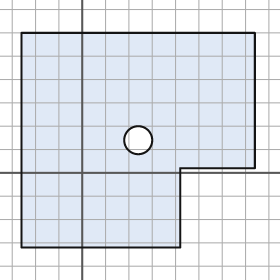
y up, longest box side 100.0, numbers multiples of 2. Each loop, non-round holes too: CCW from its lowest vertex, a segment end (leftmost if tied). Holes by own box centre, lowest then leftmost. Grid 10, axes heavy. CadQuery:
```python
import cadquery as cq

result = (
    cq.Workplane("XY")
    .moveTo(-26.0, -32.0)
    .lineTo(42.0, -32.0)
    .lineTo(42.0, 2.0)
    .lineTo(74.0, 2.0)
    .lineTo(74.0, 60.0)
    .lineTo(-26.0, 60.0)
    .close()
    .moveTo(24.0, 14.0)
    .circle(6.0)
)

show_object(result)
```